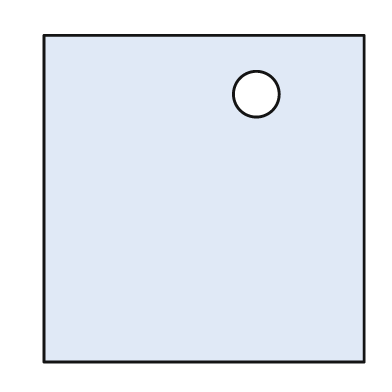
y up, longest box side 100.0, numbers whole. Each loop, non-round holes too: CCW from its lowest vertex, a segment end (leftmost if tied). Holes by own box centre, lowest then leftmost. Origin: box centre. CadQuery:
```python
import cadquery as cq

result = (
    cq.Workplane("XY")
    .moveTo(-49.0, -50.0)
    .lineTo(49.0, -50.0)
    .lineTo(49.0, 50.0)
    .lineTo(-49.0, 50.0)
    .close()
    .moveTo(16.0, 32.0)
    .circle(7.0)
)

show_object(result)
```